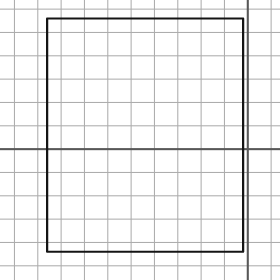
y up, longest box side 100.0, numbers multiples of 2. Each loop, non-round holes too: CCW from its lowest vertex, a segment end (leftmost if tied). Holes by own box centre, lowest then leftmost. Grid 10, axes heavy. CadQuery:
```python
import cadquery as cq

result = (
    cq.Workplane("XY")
    .moveTo(-86.0, -44.0)
    .lineTo(-2.0, -44.0)
    .lineTo(-2.0, 56.0)
    .lineTo(-86.0, 56.0)
    .close()
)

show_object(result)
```